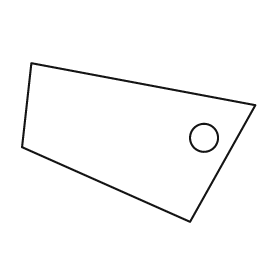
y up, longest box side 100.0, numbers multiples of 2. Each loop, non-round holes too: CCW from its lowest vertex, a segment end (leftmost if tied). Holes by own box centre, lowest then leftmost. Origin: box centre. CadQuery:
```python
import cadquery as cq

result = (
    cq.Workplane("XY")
    .moveTo(22.0, -34.0)
    .lineTo(50.0, 16.0)
    .lineTo(-46.0, 34.0)
    .lineTo(-50.0, -2.0)
    .close()
    .moveTo(28.0, 2.0)
    .circle(6.0)
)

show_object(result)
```